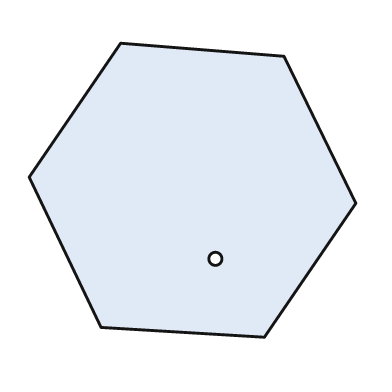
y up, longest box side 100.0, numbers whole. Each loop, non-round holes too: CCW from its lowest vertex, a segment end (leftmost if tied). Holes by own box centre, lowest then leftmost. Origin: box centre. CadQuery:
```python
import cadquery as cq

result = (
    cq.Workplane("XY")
    .moveTo(22.0, -45.0)
    .lineTo(50.0, -4.0)
    .lineTo(28.0, 41.0)
    .lineTo(-22.0, 45.0)
    .lineTo(-50.0, 4.0)
    .lineTo(-28.0, -42.0)
    .close()
    .moveTo(7.0, -21.0)
    .circle(2.0)
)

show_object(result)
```